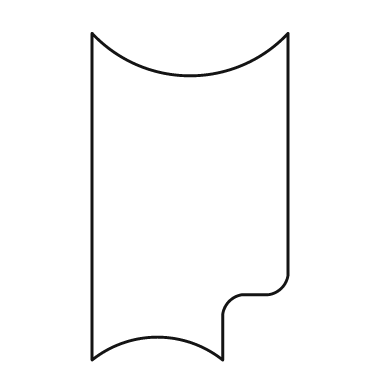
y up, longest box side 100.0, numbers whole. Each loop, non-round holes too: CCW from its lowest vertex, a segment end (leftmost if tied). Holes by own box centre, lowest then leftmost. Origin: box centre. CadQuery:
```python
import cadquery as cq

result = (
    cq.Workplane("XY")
    .moveTo(-30.0, -50.0)
    .threePointArc((-10.0, -43.0), (10.0, -50.0))
    .lineTo(10.0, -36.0)
    .threePointArc((12.0, -32.0), (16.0, -30.0))
    .lineTo(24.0, -30.0)
    .threePointArc((28.0, -28.0), (30.0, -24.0))
    .lineTo(30.0, 50.0)
    .threePointArc((0.0, 37.0), (-30.0, 50.0))
    .close()
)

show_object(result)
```